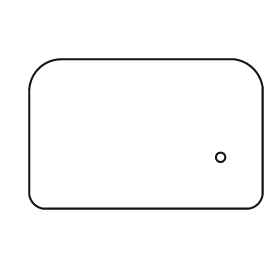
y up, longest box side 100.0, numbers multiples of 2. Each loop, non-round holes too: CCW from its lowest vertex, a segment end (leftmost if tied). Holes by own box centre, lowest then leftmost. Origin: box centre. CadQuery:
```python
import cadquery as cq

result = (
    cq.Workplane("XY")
    .moveTo(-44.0, -32.0)
    .lineTo(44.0, -32.0)
    .threePointArc((48.0, -30.0), (50.0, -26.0))
    .lineTo(50.0, 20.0)
    .threePointArc((46.0, 28.0), (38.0, 32.0))
    .lineTo(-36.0, 32.0)
    .threePointArc((-46.0, 28.0), (-50.0, 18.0))
    .lineTo(-50.0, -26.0)
    .threePointArc((-48.0, -30.0), (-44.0, -32.0))
    .close()
    .moveTo(32.0, -10.0)
    .circle(2.0)
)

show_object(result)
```